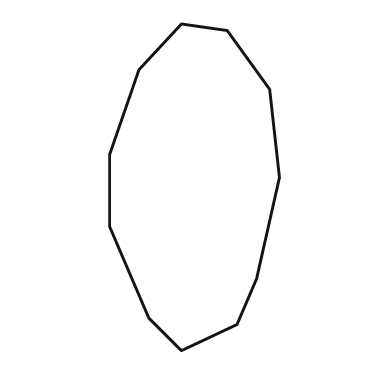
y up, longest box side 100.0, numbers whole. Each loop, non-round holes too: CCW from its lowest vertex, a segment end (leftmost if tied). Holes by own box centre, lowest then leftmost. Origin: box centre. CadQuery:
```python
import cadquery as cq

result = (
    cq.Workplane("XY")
    .moveTo(-4.0, -50.0)
    .lineTo(13.0, -42.0)
    .lineTo(19.0, -28.0)
    .lineTo(26.0, 3.0)
    .lineTo(23.0, 30.0)
    .lineTo(10.0, 48.0)
    .lineTo(-4.0, 50.0)
    .lineTo(-17.0, 36.0)
    .lineTo(-26.0, 10.0)
    .lineTo(-26.0, -12.0)
    .lineTo(-14.0, -40.0)
    .close()
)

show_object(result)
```